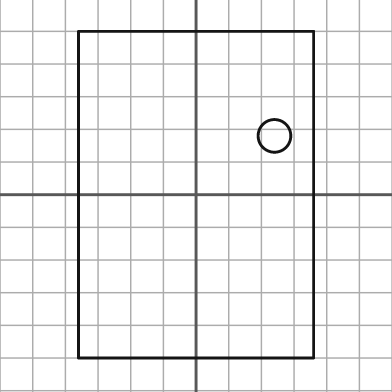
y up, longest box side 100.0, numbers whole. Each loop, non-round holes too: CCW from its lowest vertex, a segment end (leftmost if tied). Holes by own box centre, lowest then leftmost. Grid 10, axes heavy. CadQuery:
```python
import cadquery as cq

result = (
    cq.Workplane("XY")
    .moveTo(-36.0, -50.0)
    .lineTo(36.0, -50.0)
    .lineTo(36.0, 50.0)
    .lineTo(-36.0, 50.0)
    .close()
    .moveTo(24.0, 18.0)
    .circle(5.0)
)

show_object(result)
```